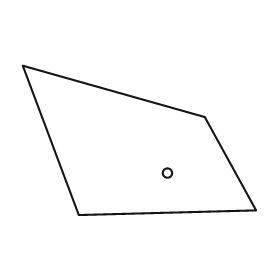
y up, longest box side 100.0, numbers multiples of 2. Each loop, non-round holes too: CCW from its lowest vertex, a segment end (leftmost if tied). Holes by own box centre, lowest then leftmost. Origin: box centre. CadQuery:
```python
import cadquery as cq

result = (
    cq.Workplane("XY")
    .moveTo(-26.0, -32.0)
    .lineTo(50.0, -30.0)
    .lineTo(28.0, 10.0)
    .lineTo(-50.0, 32.0)
    .close()
    .moveTo(12.0, -14.0)
    .circle(2.0)
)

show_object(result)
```